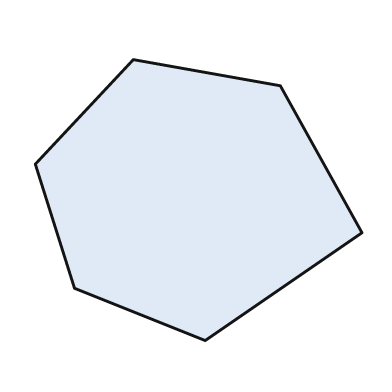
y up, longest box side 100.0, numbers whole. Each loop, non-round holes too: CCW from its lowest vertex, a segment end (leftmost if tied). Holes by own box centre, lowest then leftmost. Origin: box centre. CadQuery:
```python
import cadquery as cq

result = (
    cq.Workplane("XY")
    .moveTo(2.0, -43.0)
    .lineTo(50.0, -10.0)
    .lineTo(25.0, 35.0)
    .lineTo(-20.0, 43.0)
    .lineTo(-50.0, 11.0)
    .lineTo(-38.0, -27.0)
    .close()
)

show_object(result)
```